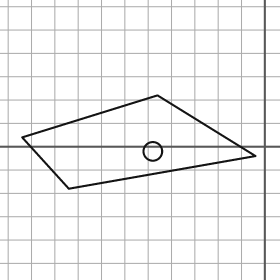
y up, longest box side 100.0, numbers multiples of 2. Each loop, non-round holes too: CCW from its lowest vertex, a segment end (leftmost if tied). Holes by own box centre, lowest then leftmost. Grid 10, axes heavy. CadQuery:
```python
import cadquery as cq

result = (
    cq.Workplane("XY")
    .moveTo(-84.0, -18.0)
    .lineTo(-4.0, -4.0)
    .lineTo(-46.0, 22.0)
    .lineTo(-104.0, 4.0)
    .close()
    .moveTo(-48.0, -2.0)
    .circle(4.0)
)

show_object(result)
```